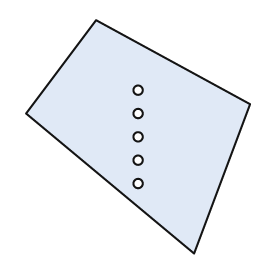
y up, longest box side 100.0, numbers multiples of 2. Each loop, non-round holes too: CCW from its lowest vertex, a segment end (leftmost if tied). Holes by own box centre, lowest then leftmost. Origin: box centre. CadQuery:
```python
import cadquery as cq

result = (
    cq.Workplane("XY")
    .moveTo(24.0, -50.0)
    .lineTo(48.0, 14.0)
    .lineTo(-18.0, 50.0)
    .lineTo(-48.0, 10.0)
    .close()
    .moveTo(0.0, -20.0)
    .circle(2.0)
    .moveTo(0.0, -10.0)
    .circle(2.0)
    .moveTo(0.0, 0.0)
    .circle(2.0)
    .moveTo(0.0, 10.0)
    .circle(2.0)
    .moveTo(0.0, 20.0)
    .circle(2.0)
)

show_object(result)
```